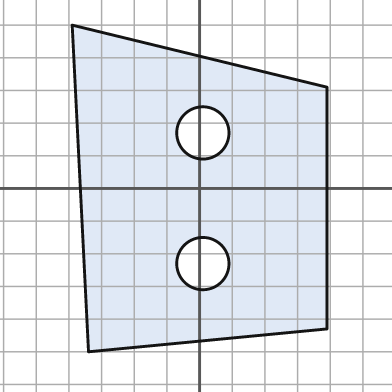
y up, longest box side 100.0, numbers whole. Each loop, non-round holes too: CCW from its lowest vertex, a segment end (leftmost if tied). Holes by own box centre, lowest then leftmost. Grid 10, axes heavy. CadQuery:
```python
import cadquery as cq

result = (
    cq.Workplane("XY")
    .moveTo(-34.0, -50.0)
    .lineTo(39.0, -43.0)
    .lineTo(39.0, 31.0)
    .lineTo(-39.0, 50.0)
    .close()
    .moveTo(1.0, -23.0)
    .circle(8.0)
    .moveTo(1.0, 17.0)
    .circle(8.0)
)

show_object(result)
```